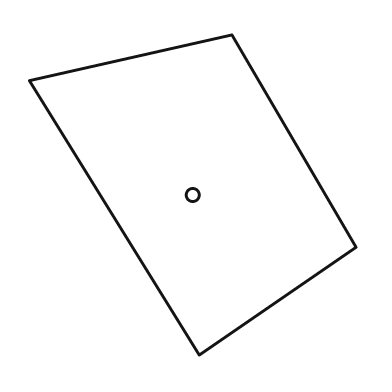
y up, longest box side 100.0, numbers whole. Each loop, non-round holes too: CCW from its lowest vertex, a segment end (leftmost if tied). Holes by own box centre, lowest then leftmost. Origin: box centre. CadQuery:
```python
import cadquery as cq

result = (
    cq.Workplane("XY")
    .moveTo(2.0, -49.0)
    .lineTo(50.0, -16.0)
    .lineTo(12.0, 49.0)
    .lineTo(-50.0, 35.0)
    .close()
    .moveTo(0.0, 0.0)
    .circle(2.0)
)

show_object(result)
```